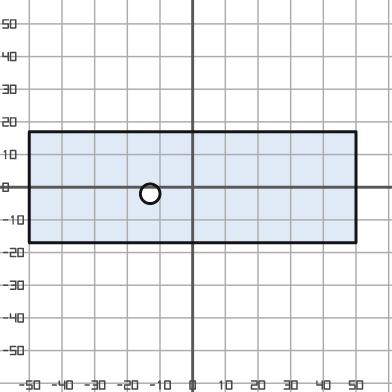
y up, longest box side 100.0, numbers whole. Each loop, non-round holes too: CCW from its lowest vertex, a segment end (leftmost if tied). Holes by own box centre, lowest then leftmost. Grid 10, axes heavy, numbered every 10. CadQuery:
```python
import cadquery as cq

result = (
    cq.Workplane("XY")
    .moveTo(-50.0, -17.0)
    .lineTo(50.0, -17.0)
    .lineTo(50.0, 17.0)
    .lineTo(-50.0, 17.0)
    .close()
    .moveTo(-13.0, -2.0)
    .circle(3.0)
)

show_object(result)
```